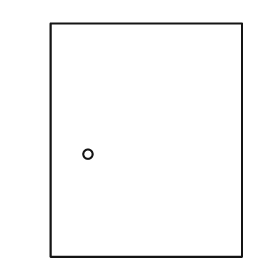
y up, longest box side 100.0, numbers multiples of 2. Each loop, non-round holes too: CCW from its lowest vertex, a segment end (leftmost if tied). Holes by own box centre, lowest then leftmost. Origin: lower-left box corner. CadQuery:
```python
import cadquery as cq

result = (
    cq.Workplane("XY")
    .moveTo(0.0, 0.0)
    .lineTo(82.0, 0.0)
    .lineTo(82.0, 100.0)
    .lineTo(0.0, 100.0)
    .close()
    .moveTo(16.0, 44.0)
    .circle(2.0)
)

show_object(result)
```